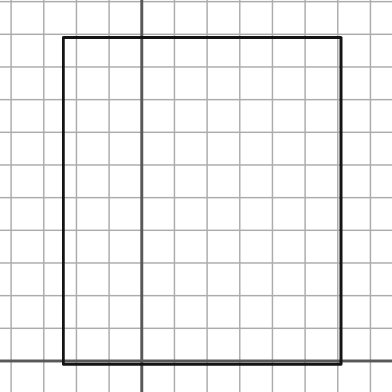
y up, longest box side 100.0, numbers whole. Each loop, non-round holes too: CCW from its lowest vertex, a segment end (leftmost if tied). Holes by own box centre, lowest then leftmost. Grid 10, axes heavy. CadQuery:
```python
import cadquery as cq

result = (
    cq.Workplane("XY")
    .moveTo(-24.0, -1.0)
    .lineTo(61.0, -1.0)
    .lineTo(61.0, 99.0)
    .lineTo(-24.0, 99.0)
    .close()
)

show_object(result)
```